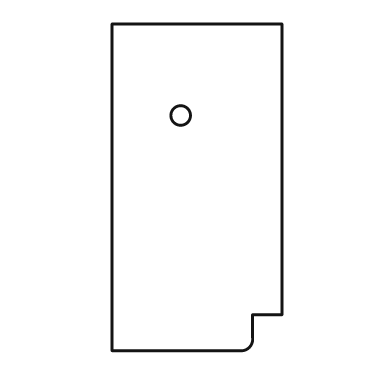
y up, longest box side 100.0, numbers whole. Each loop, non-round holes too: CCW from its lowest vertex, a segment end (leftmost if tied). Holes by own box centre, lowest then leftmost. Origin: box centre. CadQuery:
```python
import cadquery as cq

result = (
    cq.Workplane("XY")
    .moveTo(-26.0, -50.0)
    .lineTo(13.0, -50.0)
    .threePointArc((16.0, -49.0), (17.0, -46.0))
    .lineTo(17.0, -39.0)
    .lineTo(26.0, -39.0)
    .lineTo(26.0, 50.0)
    .lineTo(-26.0, 50.0)
    .close()
    .moveTo(-5.0, 22.0)
    .circle(3.0)
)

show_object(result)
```